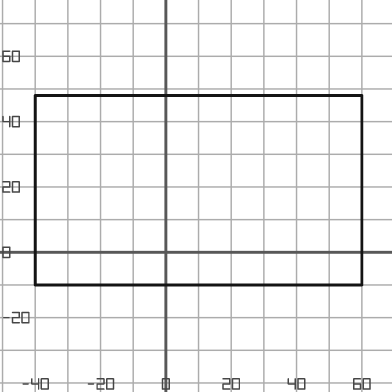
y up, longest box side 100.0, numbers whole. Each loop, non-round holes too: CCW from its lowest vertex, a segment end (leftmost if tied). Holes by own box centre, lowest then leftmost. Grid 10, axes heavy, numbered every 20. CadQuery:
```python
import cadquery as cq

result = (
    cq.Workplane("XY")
    .moveTo(-40.0, -10.0)
    .lineTo(60.0, -10.0)
    .lineTo(60.0, 48.0)
    .lineTo(-40.0, 48.0)
    .close()
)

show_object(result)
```